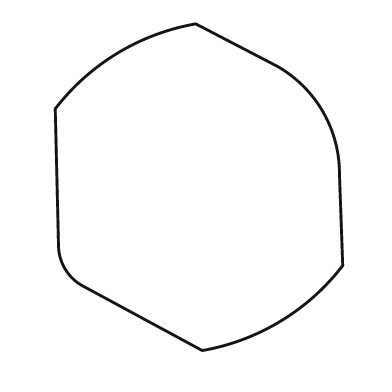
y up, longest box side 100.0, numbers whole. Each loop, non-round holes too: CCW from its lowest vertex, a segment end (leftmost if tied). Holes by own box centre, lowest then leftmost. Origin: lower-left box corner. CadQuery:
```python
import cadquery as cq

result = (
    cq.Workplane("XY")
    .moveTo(45.0, 0.0)
    .threePointArc((69.0, 9.0), (88.0, 26.0))
    .lineTo(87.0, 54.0)
    .threePointArc((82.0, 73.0), (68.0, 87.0))
    .lineTo(43.0, 100.0)
    .threePointArc((19.0, 91.0), (0.0, 74.0))
    .lineTo(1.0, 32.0)
    .threePointArc((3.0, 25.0), (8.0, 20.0))
    .close()
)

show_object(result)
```